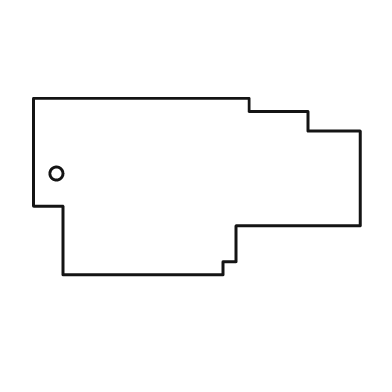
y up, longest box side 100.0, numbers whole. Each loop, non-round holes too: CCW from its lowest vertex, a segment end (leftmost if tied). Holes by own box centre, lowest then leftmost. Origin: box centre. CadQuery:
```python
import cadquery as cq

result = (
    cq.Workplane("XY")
    .moveTo(-41.0, -27.0)
    .lineTo(8.0, -27.0)
    .lineTo(8.0, -23.0)
    .lineTo(12.0, -23.0)
    .lineTo(12.0, -12.0)
    .lineTo(50.0, -12.0)
    .lineTo(50.0, 17.0)
    .lineTo(34.0, 17.0)
    .lineTo(34.0, 23.0)
    .lineTo(16.0, 23.0)
    .lineTo(16.0, 27.0)
    .lineTo(-50.0, 27.0)
    .lineTo(-50.0, -6.0)
    .lineTo(-41.0, -6.0)
    .close()
    .moveTo(-43.0, 4.0)
    .circle(2.0)
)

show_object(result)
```